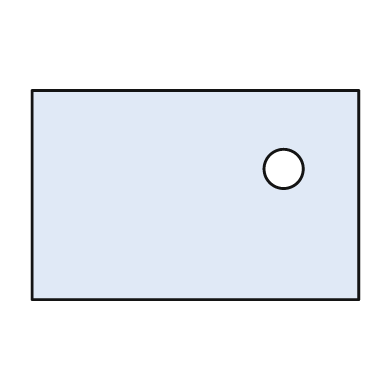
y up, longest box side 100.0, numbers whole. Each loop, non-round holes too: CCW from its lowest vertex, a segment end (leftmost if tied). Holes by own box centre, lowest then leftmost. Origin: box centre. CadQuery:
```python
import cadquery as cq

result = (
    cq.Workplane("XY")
    .moveTo(-50.0, -32.0)
    .lineTo(50.0, -32.0)
    .lineTo(50.0, 32.0)
    .lineTo(-50.0, 32.0)
    .close()
    .moveTo(27.0, 8.0)
    .circle(6.0)
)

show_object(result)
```